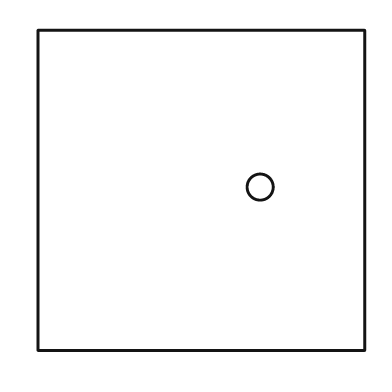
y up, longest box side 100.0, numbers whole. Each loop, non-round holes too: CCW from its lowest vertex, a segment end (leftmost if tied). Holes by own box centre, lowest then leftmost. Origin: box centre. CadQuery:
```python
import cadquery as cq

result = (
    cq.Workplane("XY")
    .moveTo(-50.0, -49.0)
    .lineTo(50.0, -49.0)
    .lineTo(50.0, 49.0)
    .lineTo(-50.0, 49.0)
    .close()
    .moveTo(18.0, 1.0)
    .circle(4.0)
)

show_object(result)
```